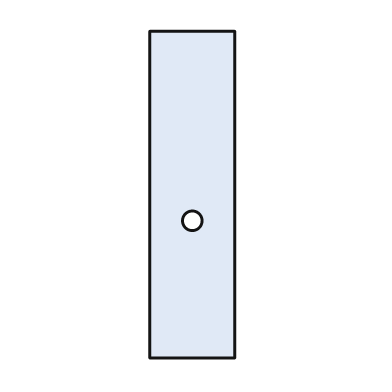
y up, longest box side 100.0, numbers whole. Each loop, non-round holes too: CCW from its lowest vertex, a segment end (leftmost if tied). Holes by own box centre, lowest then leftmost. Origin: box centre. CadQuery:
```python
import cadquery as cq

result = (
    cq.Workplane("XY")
    .moveTo(-13.0, -50.0)
    .lineTo(13.0, -50.0)
    .lineTo(13.0, 50.0)
    .lineTo(-13.0, 50.0)
    .close()
    .moveTo(0.0, -8.0)
    .circle(3.0)
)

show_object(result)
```